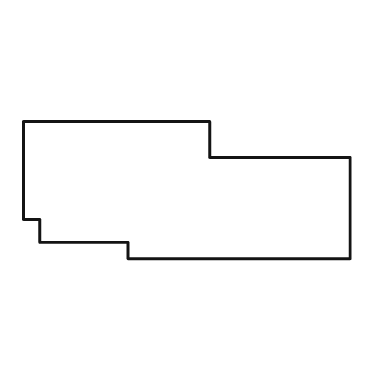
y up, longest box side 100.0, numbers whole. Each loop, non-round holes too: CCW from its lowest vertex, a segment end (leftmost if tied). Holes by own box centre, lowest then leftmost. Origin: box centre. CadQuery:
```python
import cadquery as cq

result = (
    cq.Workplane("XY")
    .moveTo(-18.0, -21.0)
    .lineTo(50.0, -21.0)
    .lineTo(50.0, 10.0)
    .lineTo(7.0, 10.0)
    .lineTo(7.0, 21.0)
    .lineTo(-50.0, 21.0)
    .lineTo(-50.0, -9.0)
    .lineTo(-45.0, -9.0)
    .lineTo(-45.0, -16.0)
    .lineTo(-18.0, -16.0)
    .close()
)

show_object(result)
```